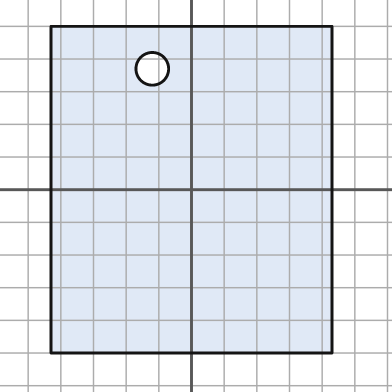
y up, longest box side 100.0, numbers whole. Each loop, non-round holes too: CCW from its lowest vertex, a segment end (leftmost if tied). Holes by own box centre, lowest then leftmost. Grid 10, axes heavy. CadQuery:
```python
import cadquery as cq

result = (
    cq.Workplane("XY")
    .moveTo(-43.0, -50.0)
    .lineTo(43.0, -50.0)
    .lineTo(43.0, 50.0)
    .lineTo(-43.0, 50.0)
    .close()
    .moveTo(-12.0, 37.0)
    .circle(5.0)
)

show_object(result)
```